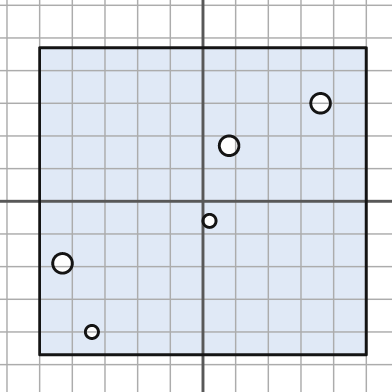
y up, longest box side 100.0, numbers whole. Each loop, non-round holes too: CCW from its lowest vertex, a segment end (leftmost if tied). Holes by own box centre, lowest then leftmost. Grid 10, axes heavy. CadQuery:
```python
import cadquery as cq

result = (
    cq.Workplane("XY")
    .moveTo(-50.0, -47.0)
    .lineTo(50.0, -47.0)
    .lineTo(50.0, 47.0)
    .lineTo(-50.0, 47.0)
    .close()
    .moveTo(-34.0, -40.0)
    .circle(2.0)
    .moveTo(-43.0, -19.0)
    .circle(3.0)
    .moveTo(2.0, -6.0)
    .circle(2.0)
    .moveTo(8.0, 17.0)
    .circle(3.0)
    .moveTo(36.0, 30.0)
    .circle(3.0)
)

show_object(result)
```